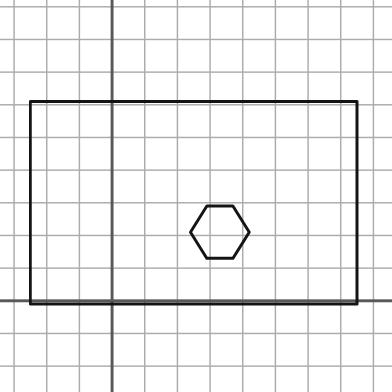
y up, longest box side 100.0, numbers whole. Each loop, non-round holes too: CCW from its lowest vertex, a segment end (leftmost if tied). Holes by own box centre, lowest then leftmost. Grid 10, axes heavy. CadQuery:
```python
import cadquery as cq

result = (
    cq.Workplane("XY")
    .moveTo(-25.0, -1.0)
    .lineTo(75.0, -1.0)
    .lineTo(75.0, 61.0)
    .lineTo(-25.0, 61.0)
    .close()
    .moveTo(29.0, 13.0)
    .lineTo(37.0, 13.0)
    .lineTo(42.0, 21.0)
    .lineTo(37.0, 29.0)
    .lineTo(29.0, 29.0)
    .lineTo(24.0, 21.0)
    .close()
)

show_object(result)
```